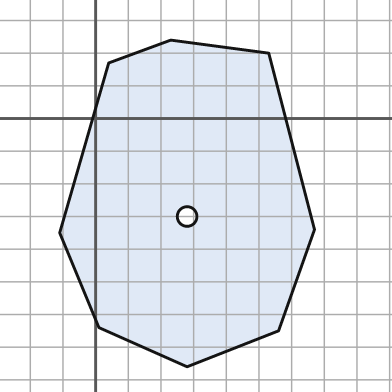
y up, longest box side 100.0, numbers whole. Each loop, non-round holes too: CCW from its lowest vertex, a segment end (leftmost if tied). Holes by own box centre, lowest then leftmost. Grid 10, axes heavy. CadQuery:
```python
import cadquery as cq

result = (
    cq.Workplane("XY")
    .moveTo(28.0, -76.0)
    .lineTo(56.0, -65.0)
    .lineTo(67.0, -34.0)
    .lineTo(53.0, 20.0)
    .lineTo(23.0, 24.0)
    .lineTo(4.0, 17.0)
    .lineTo(-11.0, -35.0)
    .lineTo(1.0, -64.0)
    .close()
    .moveTo(28.0, -30.0)
    .circle(3.0)
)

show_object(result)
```